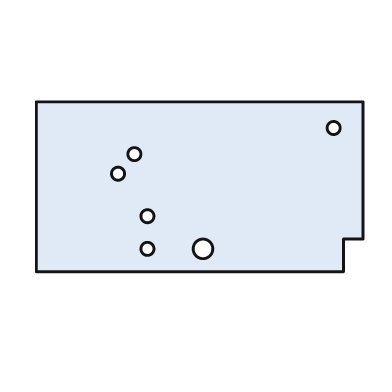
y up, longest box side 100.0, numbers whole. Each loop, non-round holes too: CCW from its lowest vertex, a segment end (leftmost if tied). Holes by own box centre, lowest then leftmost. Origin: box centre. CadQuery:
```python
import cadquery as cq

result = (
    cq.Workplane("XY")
    .moveTo(-50.0, -26.0)
    .lineTo(44.0, -26.0)
    .lineTo(44.0, -16.0)
    .lineTo(50.0, -16.0)
    .lineTo(50.0, 26.0)
    .lineTo(-50.0, 26.0)
    .close()
    .moveTo(-16.0, -19.0)
    .circle(2.0)
    .moveTo(1.0, -19.0)
    .circle(3.0)
    .moveTo(-16.0, -9.0)
    .circle(2.0)
    .moveTo(-25.0, 4.0)
    .circle(2.0)
    .moveTo(-20.0, 10.0)
    .circle(2.0)
    .moveTo(41.0, 18.0)
    .circle(2.0)
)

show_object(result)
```